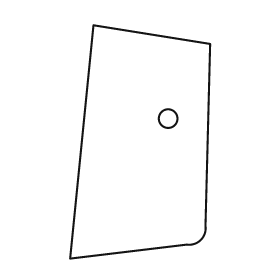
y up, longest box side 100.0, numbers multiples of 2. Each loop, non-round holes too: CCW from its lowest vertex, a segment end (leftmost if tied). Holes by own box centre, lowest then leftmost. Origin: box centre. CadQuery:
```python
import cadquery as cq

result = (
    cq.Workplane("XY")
    .moveTo(-30.0, -50.0)
    .lineTo(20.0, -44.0)
    .threePointArc((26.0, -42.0), (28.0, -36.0))
    .lineTo(30.0, 42.0)
    .lineTo(-20.0, 50.0)
    .close()
    .moveTo(12.0, 10.0)
    .circle(4.0)
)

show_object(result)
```